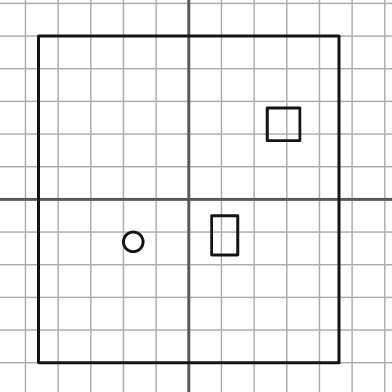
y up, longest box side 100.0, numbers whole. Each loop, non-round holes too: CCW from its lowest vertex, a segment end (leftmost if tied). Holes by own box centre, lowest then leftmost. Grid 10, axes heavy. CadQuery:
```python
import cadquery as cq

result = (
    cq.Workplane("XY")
    .moveTo(-46.0, -50.0)
    .lineTo(46.0, -50.0)
    .lineTo(46.0, 50.0)
    .lineTo(-46.0, 50.0)
    .close()
    .moveTo(-17.0, -13.0)
    .circle(3.0)
    .moveTo(7.0, -17.0)
    .lineTo(15.0, -17.0)
    .lineTo(15.0, -5.0)
    .lineTo(7.0, -5.0)
    .close()
    .moveTo(24.0, 18.0)
    .lineTo(34.0, 18.0)
    .lineTo(34.0, 28.0)
    .lineTo(24.0, 28.0)
    .close()
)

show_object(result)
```